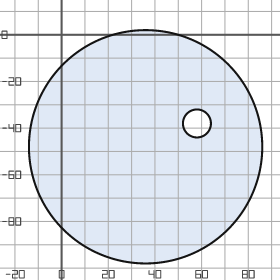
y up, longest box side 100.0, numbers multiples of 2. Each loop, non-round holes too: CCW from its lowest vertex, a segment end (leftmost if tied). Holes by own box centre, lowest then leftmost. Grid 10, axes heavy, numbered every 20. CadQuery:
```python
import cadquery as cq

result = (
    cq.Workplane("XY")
    .moveTo(36.0, -48.0)
    .circle(50.0)
    .moveTo(58.0, -38.0)
    .circle(6.0)
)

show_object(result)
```